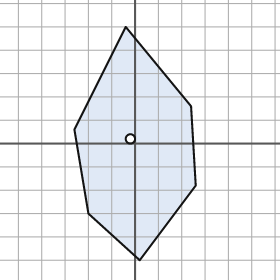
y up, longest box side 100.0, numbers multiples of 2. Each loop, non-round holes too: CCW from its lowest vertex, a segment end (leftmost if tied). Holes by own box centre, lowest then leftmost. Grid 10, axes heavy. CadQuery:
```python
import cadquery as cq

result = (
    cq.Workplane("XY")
    .moveTo(2.0, -50.0)
    .lineTo(26.0, -18.0)
    .lineTo(24.0, 16.0)
    .lineTo(-4.0, 50.0)
    .lineTo(-26.0, 6.0)
    .lineTo(-20.0, -30.0)
    .close()
    .moveTo(-2.0, 2.0)
    .circle(2.0)
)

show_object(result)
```